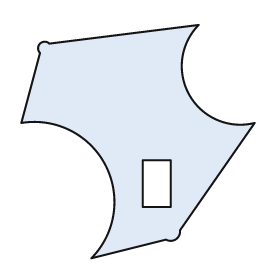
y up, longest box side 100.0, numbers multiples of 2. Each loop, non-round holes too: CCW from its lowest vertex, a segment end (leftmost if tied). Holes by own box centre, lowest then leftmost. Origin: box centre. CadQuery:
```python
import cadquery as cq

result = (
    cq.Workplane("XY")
    .moveTo(-20.0, -50.0)
    .lineTo(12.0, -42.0)
    .threePointArc((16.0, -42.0), (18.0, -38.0))
    .lineTo(50.0, 8.0)
    .threePointArc((22.0, 20.0), (26.0, 50.0))
    .lineTo(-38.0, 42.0)
    .threePointArc((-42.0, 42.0), (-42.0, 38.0))
    .lineTo(-50.0, 8.0)
    .threePointArc((-14.0, -10.0), (-20.0, -50.0))
    .close()
    .moveTo(2.0, -28.0)
    .lineTo(14.0, -28.0)
    .lineTo(14.0, -8.0)
    .lineTo(2.0, -8.0)
    .close()
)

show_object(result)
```